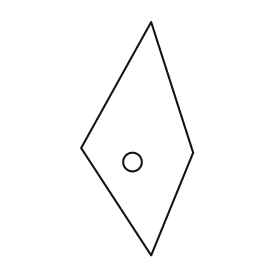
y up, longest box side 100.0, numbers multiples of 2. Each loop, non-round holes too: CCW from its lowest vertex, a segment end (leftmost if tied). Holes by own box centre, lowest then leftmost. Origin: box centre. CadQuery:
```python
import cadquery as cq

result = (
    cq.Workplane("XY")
    .moveTo(6.0, -50.0)
    .lineTo(24.0, -6.0)
    .lineTo(6.0, 50.0)
    .lineTo(-24.0, -4.0)
    .close()
    .moveTo(-2.0, -10.0)
    .circle(4.0)
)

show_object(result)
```